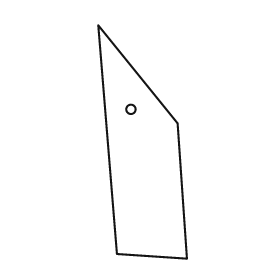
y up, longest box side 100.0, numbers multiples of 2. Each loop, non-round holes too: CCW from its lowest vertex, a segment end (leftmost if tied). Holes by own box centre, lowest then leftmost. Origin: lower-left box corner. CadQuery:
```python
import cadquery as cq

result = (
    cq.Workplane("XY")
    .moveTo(38.0, 0.0)
    .lineTo(34.0, 58.0)
    .lineTo(0.0, 100.0)
    .lineTo(8.0, 2.0)
    .close()
    .moveTo(14.0, 64.0)
    .circle(2.0)
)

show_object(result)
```